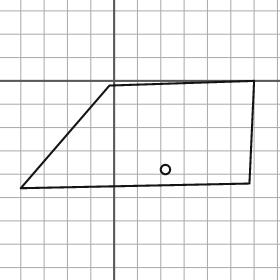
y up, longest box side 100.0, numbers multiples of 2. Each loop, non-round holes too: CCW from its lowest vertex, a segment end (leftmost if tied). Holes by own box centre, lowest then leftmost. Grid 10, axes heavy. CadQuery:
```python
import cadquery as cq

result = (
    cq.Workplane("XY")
    .moveTo(-40.0, -46.0)
    .lineTo(58.0, -44.0)
    .lineTo(60.0, 0.0)
    .lineTo(-2.0, -2.0)
    .close()
    .moveTo(22.0, -38.0)
    .circle(2.0)
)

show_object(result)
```